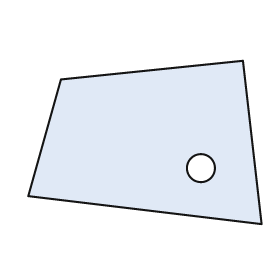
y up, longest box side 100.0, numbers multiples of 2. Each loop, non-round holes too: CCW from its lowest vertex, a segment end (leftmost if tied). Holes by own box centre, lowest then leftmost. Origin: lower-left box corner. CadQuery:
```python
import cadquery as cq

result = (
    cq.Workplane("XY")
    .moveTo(100.0, 0.0)
    .lineTo(92.0, 70.0)
    .lineTo(14.0, 62.0)
    .lineTo(0.0, 12.0)
    .close()
    .moveTo(74.0, 24.0)
    .circle(6.0)
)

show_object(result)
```